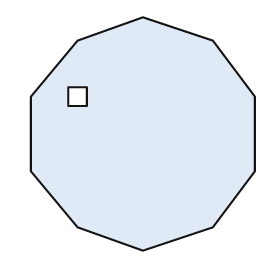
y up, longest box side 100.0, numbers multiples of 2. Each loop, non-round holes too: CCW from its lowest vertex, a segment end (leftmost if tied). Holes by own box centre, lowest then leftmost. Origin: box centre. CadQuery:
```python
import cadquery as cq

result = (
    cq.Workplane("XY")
    .moveTo(0.0, -50.0)
    .lineTo(30.0, -40.0)
    .lineTo(48.0, -16.0)
    .lineTo(48.0, 16.0)
    .lineTo(30.0, 40.0)
    .lineTo(0.0, 50.0)
    .lineTo(-28.0, 40.0)
    .lineTo(-48.0, 16.0)
    .lineTo(-48.0, -16.0)
    .lineTo(-28.0, -40.0)
    .close()
    .moveTo(-32.0, 12.0)
    .lineTo(-24.0, 12.0)
    .lineTo(-24.0, 20.0)
    .lineTo(-32.0, 20.0)
    .close()
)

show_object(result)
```